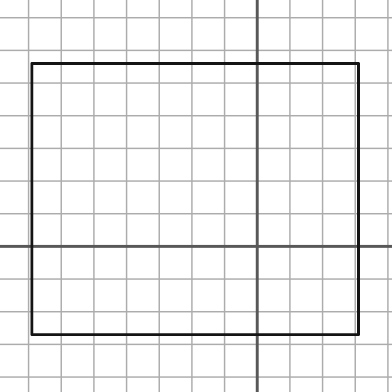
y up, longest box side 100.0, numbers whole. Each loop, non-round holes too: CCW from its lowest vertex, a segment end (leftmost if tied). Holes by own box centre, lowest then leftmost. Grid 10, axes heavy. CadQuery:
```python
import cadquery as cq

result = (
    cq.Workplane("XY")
    .moveTo(-69.0, -27.0)
    .lineTo(31.0, -27.0)
    .lineTo(31.0, 56.0)
    .lineTo(-69.0, 56.0)
    .close()
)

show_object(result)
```